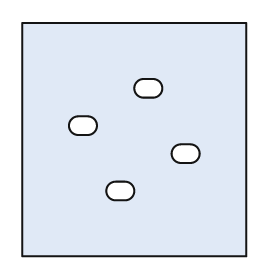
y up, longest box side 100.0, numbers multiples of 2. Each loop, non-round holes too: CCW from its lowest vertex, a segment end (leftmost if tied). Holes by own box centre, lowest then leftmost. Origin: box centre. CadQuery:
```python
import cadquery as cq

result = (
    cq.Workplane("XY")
    .moveTo(-48.0, -50.0)
    .lineTo(48.0, -50.0)
    .lineTo(48.0, 50.0)
    .lineTo(-48.0, 50.0)
    .close()
    .moveTo(-8.0, -26.0)
    .lineTo(-4.0, -26.0)
    .threePointArc((0.0, -22.0), (-4.0, -18.0))
    .lineTo(-8.0, -18.0)
    .threePointArc((-12.0, -22.0), (-8.0, -26.0))
    .close()
    .moveTo(20.0, -10.0)
    .lineTo(24.0, -10.0)
    .threePointArc((28.0, -6.0), (24.0, -2.0))
    .lineTo(20.0, -2.0)
    .threePointArc((16.0, -6.0), (20.0, -10.0))
    .close()
    .moveTo(-24.0, 2.0)
    .lineTo(-20.0, 2.0)
    .threePointArc((-16.0, 6.0), (-20.0, 10.0))
    .lineTo(-24.0, 10.0)
    .threePointArc((-28.0, 6.0), (-24.0, 2.0))
    .close()
    .moveTo(4.0, 18.0)
    .lineTo(8.0, 18.0)
    .threePointArc((12.0, 22.0), (8.0, 26.0))
    .lineTo(4.0, 26.0)
    .threePointArc((0.0, 22.0), (4.0, 18.0))
    .close()
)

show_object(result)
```